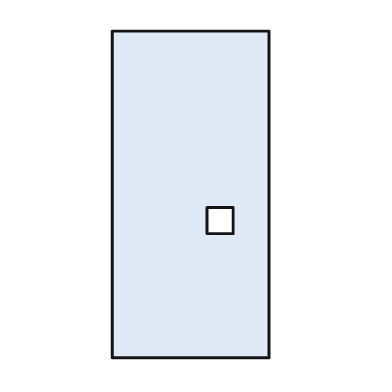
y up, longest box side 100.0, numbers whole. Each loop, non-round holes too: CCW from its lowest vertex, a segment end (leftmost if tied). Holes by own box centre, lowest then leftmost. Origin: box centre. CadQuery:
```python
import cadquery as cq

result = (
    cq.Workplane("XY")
    .moveTo(-24.0, -50.0)
    .lineTo(24.0, -50.0)
    .lineTo(24.0, 50.0)
    .lineTo(-24.0, 50.0)
    .close()
    .moveTo(5.0, -12.0)
    .lineTo(13.0, -12.0)
    .lineTo(13.0, -4.0)
    .lineTo(5.0, -4.0)
    .close()
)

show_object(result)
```